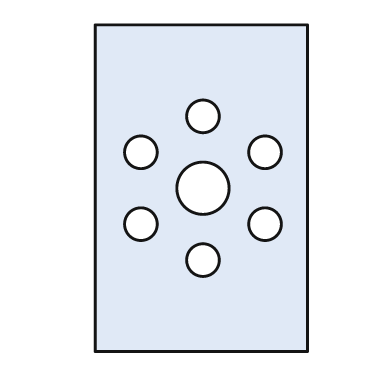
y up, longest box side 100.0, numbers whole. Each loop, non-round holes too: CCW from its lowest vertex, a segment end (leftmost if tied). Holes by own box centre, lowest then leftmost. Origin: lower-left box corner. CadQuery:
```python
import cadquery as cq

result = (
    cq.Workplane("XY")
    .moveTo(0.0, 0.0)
    .lineTo(65.0, 0.0)
    .lineTo(65.0, 100.0)
    .lineTo(0.0, 100.0)
    .close()
    .moveTo(33.0, 28.0)
    .circle(5.0)
    .moveTo(14.0, 39.0)
    .circle(5.0)
    .moveTo(52.0, 39.0)
    .circle(5.0)
    .moveTo(33.0, 50.0)
    .circle(8.0)
    .moveTo(14.0, 61.0)
    .circle(5.0)
    .moveTo(52.0, 61.0)
    .circle(5.0)
    .moveTo(33.0, 72.0)
    .circle(5.0)
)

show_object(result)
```